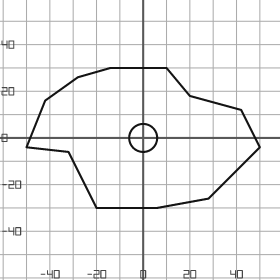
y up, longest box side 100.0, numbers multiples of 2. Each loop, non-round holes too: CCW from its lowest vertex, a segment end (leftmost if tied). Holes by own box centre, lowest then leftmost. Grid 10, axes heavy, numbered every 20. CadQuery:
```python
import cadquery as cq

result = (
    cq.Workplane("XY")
    .moveTo(-20.0, -30.0)
    .lineTo(6.0, -30.0)
    .lineTo(28.0, -26.0)
    .lineTo(50.0, -4.0)
    .lineTo(42.0, 12.0)
    .lineTo(20.0, 18.0)
    .lineTo(10.0, 30.0)
    .lineTo(-14.0, 30.0)
    .lineTo(-28.0, 26.0)
    .lineTo(-42.0, 16.0)
    .lineTo(-50.0, -4.0)
    .lineTo(-32.0, -6.0)
    .close()
    .moveTo(0.0, 0.0)
    .circle(6.0)
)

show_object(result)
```